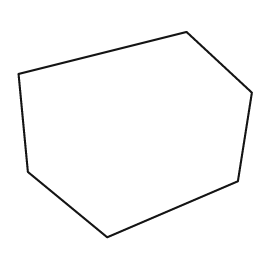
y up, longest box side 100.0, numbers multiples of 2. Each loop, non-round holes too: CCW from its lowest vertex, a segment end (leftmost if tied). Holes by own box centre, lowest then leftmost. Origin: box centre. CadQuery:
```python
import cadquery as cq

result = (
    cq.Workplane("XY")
    .moveTo(-12.0, -44.0)
    .lineTo(44.0, -20.0)
    .lineTo(50.0, 18.0)
    .lineTo(22.0, 44.0)
    .lineTo(-50.0, 26.0)
    .lineTo(-46.0, -16.0)
    .close()
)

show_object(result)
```